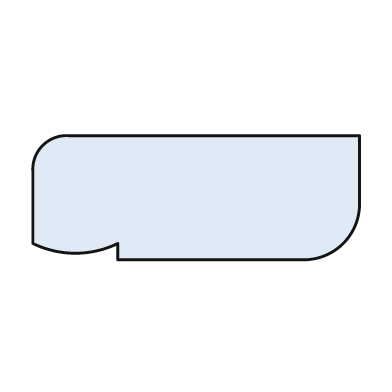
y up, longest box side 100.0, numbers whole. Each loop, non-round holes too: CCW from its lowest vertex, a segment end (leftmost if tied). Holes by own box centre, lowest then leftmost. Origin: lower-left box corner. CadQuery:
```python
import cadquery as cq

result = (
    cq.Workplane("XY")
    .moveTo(26.0, 0.0)
    .lineTo(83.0, 0.0)
    .threePointArc((95.0, 5.0), (100.0, 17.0))
    .lineTo(100.0, 38.0)
    .lineTo(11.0, 38.0)
    .threePointArc((3.0, 35.0), (0.0, 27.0))
    .lineTo(0.0, 5.0)
    .threePointArc((13.0, 2.0), (26.0, 5.0))
    .close()
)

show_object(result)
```